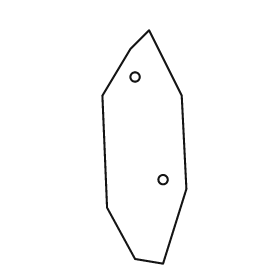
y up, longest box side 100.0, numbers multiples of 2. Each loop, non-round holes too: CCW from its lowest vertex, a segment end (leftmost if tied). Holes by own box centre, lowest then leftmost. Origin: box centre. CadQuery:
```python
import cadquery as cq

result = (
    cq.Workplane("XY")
    .moveTo(8.0, -50.0)
    .lineTo(18.0, -18.0)
    .lineTo(16.0, 22.0)
    .lineTo(2.0, 50.0)
    .lineTo(-6.0, 42.0)
    .lineTo(-18.0, 22.0)
    .lineTo(-16.0, -26.0)
    .lineTo(-4.0, -48.0)
    .close()
    .moveTo(8.0, -14.0)
    .circle(2.0)
    .moveTo(-4.0, 30.0)
    .circle(2.0)
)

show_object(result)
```